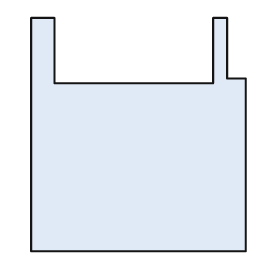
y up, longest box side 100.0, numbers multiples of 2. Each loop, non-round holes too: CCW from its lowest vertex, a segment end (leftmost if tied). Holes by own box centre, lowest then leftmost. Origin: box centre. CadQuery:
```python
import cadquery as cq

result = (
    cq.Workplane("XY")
    .moveTo(-46.0, -50.0)
    .lineTo(46.0, -50.0)
    .lineTo(46.0, 24.0)
    .lineTo(38.0, 24.0)
    .lineTo(38.0, 50.0)
    .lineTo(32.0, 50.0)
    .lineTo(32.0, 22.0)
    .lineTo(-36.0, 22.0)
    .lineTo(-36.0, 50.0)
    .lineTo(-46.0, 50.0)
    .close()
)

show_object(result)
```